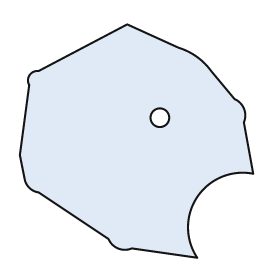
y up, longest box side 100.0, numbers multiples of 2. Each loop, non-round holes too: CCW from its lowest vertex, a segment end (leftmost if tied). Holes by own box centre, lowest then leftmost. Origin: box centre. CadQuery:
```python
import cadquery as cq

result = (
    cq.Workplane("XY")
    .moveTo(26.0, -50.0)
    .threePointArc((26.0, -24.0), (50.0, -14.0))
    .lineTo(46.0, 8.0)
    .threePointArc((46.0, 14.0), (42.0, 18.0))
    .lineTo(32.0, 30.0)
    .threePointArc((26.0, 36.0), (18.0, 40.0))
    .lineTo(-4.0, 50.0)
    .lineTo(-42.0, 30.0)
    .threePointArc((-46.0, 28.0), (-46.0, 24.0))
    .lineTo(-50.0, -6.0)
    .lineTo(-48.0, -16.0)
    .threePointArc((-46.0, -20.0), (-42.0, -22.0))
    .lineTo(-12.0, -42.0)
    .threePointArc((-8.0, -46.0), (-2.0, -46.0))
    .close()
    .moveTo(10.0, 10.0)
    .circle(4.0)
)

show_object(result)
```